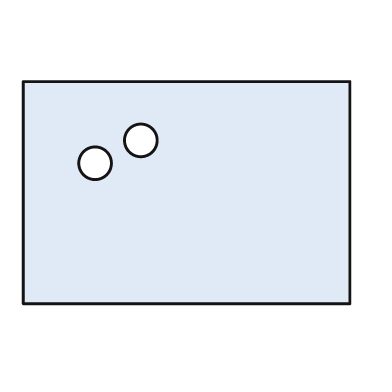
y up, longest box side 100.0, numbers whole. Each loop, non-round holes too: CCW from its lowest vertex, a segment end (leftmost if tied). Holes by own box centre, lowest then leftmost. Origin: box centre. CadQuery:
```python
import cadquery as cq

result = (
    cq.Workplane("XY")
    .moveTo(-50.0, -34.0)
    .lineTo(50.0, -34.0)
    .lineTo(50.0, 34.0)
    .lineTo(-50.0, 34.0)
    .close()
    .moveTo(-28.0, 9.0)
    .circle(5.0)
    .moveTo(-14.0, 16.0)
    .circle(5.0)
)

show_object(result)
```